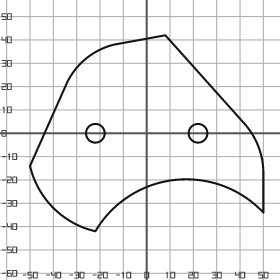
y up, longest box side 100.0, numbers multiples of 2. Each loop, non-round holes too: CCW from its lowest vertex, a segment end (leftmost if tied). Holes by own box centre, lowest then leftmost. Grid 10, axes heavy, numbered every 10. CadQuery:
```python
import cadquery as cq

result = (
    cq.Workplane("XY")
    .moveTo(-22.0, -42.0)
    .threePointArc((12.0, -20.0), (50.0, -34.0))
    .lineTo(50.0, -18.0)
    .threePointArc((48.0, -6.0), (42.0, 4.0))
    .lineTo(8.0, 42.0)
    .lineTo(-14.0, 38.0)
    .threePointArc((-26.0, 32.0), (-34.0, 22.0))
    .lineTo(-50.0, -14.0)
    .threePointArc((-40.0, -32.0), (-22.0, -42.0))
    .close()
    .moveTo(-22.0, 0.0)
    .circle(4.0)
    .moveTo(22.0, 0.0)
    .circle(4.0)
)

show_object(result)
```